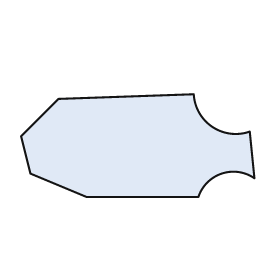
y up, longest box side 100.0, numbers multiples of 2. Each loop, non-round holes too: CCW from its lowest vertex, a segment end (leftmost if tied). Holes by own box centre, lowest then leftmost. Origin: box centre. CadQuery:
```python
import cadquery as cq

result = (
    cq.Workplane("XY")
    .moveTo(-22.0, -22.0)
    .lineTo(26.0, -22.0)
    .threePointArc((36.0, -12.0), (50.0, -14.0))
    .lineTo(48.0, 6.0)
    .threePointArc((32.0, 8.0), (24.0, 22.0))
    .lineTo(-34.0, 20.0)
    .lineTo(-50.0, 4.0)
    .lineTo(-46.0, -12.0)
    .close()
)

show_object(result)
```